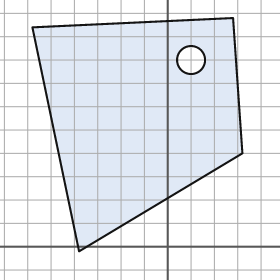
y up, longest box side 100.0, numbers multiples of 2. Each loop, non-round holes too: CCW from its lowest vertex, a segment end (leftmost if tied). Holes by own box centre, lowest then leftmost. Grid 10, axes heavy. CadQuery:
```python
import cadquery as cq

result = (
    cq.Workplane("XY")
    .moveTo(-38.0, -2.0)
    .lineTo(32.0, 40.0)
    .lineTo(28.0, 98.0)
    .lineTo(-58.0, 94.0)
    .close()
    .moveTo(10.0, 80.0)
    .circle(6.0)
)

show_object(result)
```